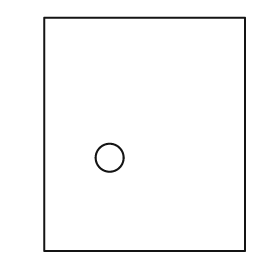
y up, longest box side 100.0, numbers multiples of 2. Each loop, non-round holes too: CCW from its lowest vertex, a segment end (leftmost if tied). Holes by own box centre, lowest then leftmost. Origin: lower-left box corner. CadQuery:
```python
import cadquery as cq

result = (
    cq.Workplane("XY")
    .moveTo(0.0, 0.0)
    .lineTo(86.0, 0.0)
    .lineTo(86.0, 100.0)
    .lineTo(0.0, 100.0)
    .close()
    .moveTo(28.0, 40.0)
    .circle(6.0)
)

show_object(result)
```